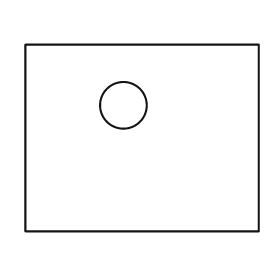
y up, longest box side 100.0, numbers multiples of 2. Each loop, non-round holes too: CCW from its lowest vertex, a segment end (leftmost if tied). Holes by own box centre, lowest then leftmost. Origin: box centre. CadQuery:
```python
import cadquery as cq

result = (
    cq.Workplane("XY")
    .moveTo(-50.0, -40.0)
    .lineTo(50.0, -40.0)
    .lineTo(50.0, 40.0)
    .lineTo(-50.0, 40.0)
    .close()
    .moveTo(-8.0, 14.0)
    .circle(10.0)
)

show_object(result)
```